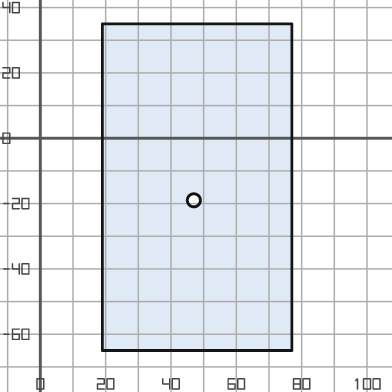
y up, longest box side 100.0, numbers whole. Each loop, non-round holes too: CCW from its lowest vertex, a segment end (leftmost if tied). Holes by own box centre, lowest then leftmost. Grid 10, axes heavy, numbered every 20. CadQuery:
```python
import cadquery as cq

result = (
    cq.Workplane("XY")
    .moveTo(19.0, -65.0)
    .lineTo(77.0, -65.0)
    .lineTo(77.0, 35.0)
    .lineTo(19.0, 35.0)
    .close()
    .moveTo(47.0, -19.0)
    .circle(2.0)
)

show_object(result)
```